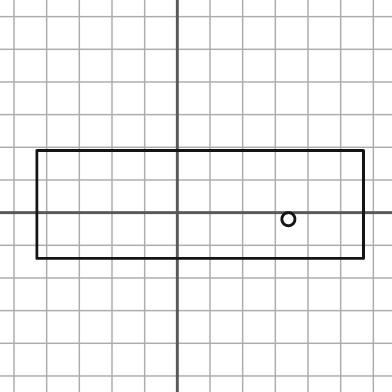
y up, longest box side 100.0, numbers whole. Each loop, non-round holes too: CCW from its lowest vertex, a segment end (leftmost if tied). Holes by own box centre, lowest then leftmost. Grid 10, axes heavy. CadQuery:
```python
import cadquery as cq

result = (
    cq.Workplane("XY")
    .moveTo(-43.0, -14.0)
    .lineTo(57.0, -14.0)
    .lineTo(57.0, 19.0)
    .lineTo(-43.0, 19.0)
    .close()
    .moveTo(34.0, -2.0)
    .circle(2.0)
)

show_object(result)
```